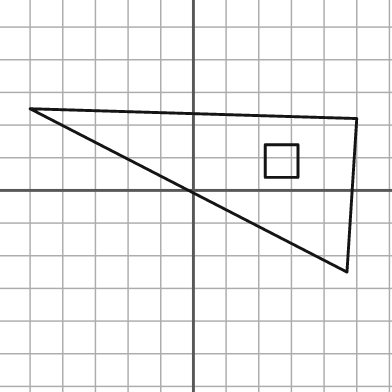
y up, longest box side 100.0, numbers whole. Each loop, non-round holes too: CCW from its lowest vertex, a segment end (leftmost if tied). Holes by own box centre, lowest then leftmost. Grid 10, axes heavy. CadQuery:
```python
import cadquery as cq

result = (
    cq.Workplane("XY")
    .moveTo(47.0, -25.0)
    .lineTo(50.0, 22.0)
    .lineTo(-50.0, 25.0)
    .close()
    .moveTo(22.0, 4.0)
    .lineTo(32.0, 4.0)
    .lineTo(32.0, 14.0)
    .lineTo(22.0, 14.0)
    .close()
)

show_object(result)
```